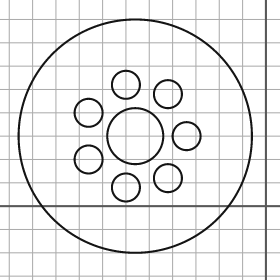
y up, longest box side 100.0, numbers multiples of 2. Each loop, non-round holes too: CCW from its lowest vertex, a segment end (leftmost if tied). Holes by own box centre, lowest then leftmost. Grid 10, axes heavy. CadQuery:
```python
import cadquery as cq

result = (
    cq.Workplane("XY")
    .moveTo(-56.0, 30.0)
    .circle(50.0)
    .moveTo(-60.0, 8.0)
    .circle(6.0)
    .moveTo(-42.0, 12.0)
    .circle(6.0)
    .moveTo(-76.0, 20.0)
    .circle(6.0)
    .moveTo(-56.0, 30.0)
    .circle(12.0)
    .moveTo(-34.0, 30.0)
    .circle(6.0)
    .moveTo(-76.0, 40.0)
    .circle(6.0)
    .moveTo(-42.0, 48.0)
    .circle(6.0)
    .moveTo(-60.0, 52.0)
    .circle(6.0)
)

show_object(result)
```